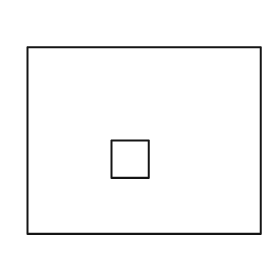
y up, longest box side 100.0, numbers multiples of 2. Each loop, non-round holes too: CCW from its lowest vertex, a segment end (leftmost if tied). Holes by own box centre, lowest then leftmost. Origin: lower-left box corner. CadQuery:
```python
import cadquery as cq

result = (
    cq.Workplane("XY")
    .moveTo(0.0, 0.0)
    .lineTo(100.0, 0.0)
    .lineTo(100.0, 80.0)
    .lineTo(0.0, 80.0)
    .close()
    .moveTo(36.0, 24.0)
    .lineTo(52.0, 24.0)
    .lineTo(52.0, 40.0)
    .lineTo(36.0, 40.0)
    .close()
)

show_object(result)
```